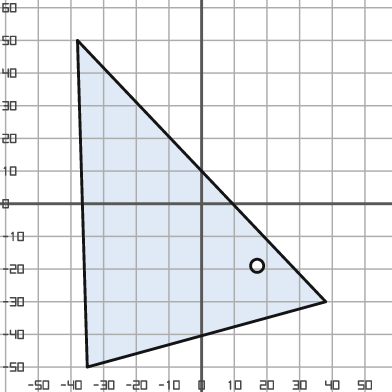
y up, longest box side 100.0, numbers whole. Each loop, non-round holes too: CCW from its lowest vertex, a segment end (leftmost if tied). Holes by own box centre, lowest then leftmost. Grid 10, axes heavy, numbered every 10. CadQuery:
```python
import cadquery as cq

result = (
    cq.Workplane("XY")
    .moveTo(-35.0, -50.0)
    .lineTo(38.0, -30.0)
    .lineTo(-38.0, 50.0)
    .close()
    .moveTo(17.0, -19.0)
    .circle(2.0)
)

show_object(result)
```